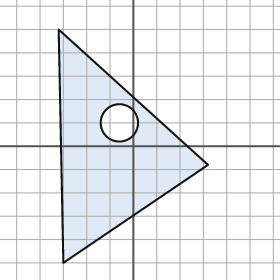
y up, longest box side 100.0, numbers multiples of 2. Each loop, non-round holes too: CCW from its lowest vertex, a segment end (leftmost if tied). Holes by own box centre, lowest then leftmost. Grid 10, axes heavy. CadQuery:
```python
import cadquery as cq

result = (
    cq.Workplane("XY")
    .moveTo(-30.0, -50.0)
    .lineTo(32.0, -8.0)
    .lineTo(-32.0, 50.0)
    .close()
    .moveTo(-6.0, 10.0)
    .circle(8.0)
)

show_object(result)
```